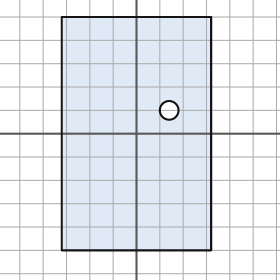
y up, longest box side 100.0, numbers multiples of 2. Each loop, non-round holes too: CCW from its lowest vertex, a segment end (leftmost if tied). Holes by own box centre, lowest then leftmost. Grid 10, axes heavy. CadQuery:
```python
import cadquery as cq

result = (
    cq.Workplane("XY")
    .moveTo(-32.0, -50.0)
    .lineTo(32.0, -50.0)
    .lineTo(32.0, 50.0)
    .lineTo(-32.0, 50.0)
    .close()
    .moveTo(14.0, 10.0)
    .circle(4.0)
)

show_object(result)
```